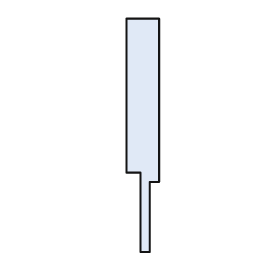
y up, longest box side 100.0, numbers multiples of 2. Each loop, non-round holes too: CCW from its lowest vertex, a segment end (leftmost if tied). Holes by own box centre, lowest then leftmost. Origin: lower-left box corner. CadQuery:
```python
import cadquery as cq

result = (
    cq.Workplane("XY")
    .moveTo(6.0, 0.0)
    .lineTo(10.0, 0.0)
    .lineTo(10.0, 30.0)
    .lineTo(14.0, 30.0)
    .lineTo(14.0, 100.0)
    .lineTo(0.0, 100.0)
    .lineTo(0.0, 34.0)
    .lineTo(6.0, 34.0)
    .close()
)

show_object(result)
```